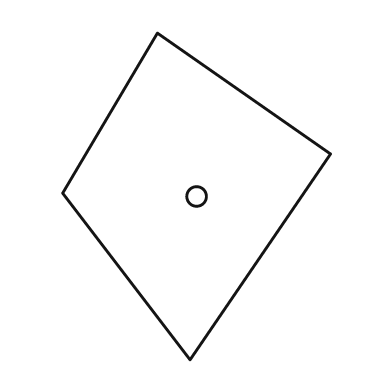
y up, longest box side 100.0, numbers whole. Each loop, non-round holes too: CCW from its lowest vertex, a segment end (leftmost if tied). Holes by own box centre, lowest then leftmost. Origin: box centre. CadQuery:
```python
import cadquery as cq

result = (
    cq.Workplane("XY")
    .moveTo(-2.0, -50.0)
    .lineTo(41.0, 13.0)
    .lineTo(-12.0, 50.0)
    .lineTo(-41.0, 1.0)
    .close()
    .moveTo(0.0, 0.0)
    .circle(3.0)
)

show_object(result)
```